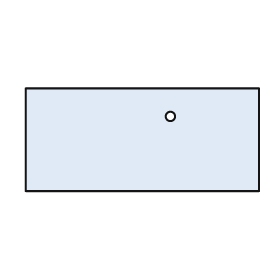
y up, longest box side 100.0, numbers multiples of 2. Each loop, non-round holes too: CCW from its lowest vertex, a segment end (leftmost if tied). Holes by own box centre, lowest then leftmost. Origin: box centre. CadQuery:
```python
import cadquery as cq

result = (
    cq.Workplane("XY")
    .moveTo(-50.0, -22.0)
    .lineTo(50.0, -22.0)
    .lineTo(50.0, 22.0)
    .lineTo(-50.0, 22.0)
    .close()
    .moveTo(12.0, 10.0)
    .circle(2.0)
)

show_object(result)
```